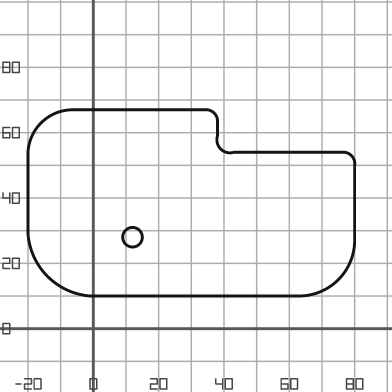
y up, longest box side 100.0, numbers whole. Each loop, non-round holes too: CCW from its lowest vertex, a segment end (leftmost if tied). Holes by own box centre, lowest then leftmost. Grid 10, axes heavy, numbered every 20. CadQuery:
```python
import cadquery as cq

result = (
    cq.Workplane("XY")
    .moveTo(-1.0, 10.0)
    .lineTo(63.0, 10.0)
    .threePointArc((75.0, 15.0), (80.0, 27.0))
    .lineTo(80.0, 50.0)
    .threePointArc((79.0, 53.0), (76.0, 54.0))
    .lineTo(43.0, 54.0)
    .threePointArc((39.0, 55.0), (38.0, 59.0))
    .lineTo(38.0, 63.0)
    .threePointArc((37.0, 66.0), (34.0, 67.0))
    .lineTo(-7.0, 67.0)
    .threePointArc((-16.0, 63.0), (-20.0, 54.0))
    .lineTo(-20.0, 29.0)
    .threePointArc((-14.0, 16.0), (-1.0, 10.0))
    .close()
    .moveTo(12.0, 28.0)
    .circle(3.0)
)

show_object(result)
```